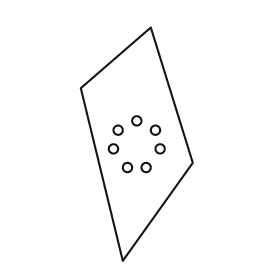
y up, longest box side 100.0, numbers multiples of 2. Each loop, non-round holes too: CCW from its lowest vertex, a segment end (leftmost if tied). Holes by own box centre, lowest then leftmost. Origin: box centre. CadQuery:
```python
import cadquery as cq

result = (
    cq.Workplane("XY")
    .moveTo(-6.0, -50.0)
    .lineTo(24.0, -8.0)
    .lineTo(6.0, 50.0)
    .lineTo(-24.0, 24.0)
    .close()
    .moveTo(-4.0, -10.0)
    .circle(2.0)
    .moveTo(4.0, -10.0)
    .circle(2.0)
    .moveTo(-10.0, -2.0)
    .circle(2.0)
    .moveTo(10.0, -2.0)
    .circle(2.0)
    .moveTo(-8.0, 6.0)
    .circle(2.0)
    .moveTo(8.0, 6.0)
    .circle(2.0)
    .moveTo(0.0, 10.0)
    .circle(2.0)
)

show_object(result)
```